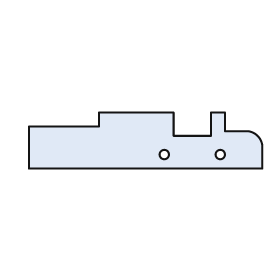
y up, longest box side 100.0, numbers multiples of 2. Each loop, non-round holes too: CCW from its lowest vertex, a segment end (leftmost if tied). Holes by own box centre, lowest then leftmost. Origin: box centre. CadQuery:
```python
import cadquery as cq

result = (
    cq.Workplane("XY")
    .moveTo(-50.0, -12.0)
    .lineTo(50.0, -12.0)
    .lineTo(50.0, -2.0)
    .threePointArc((48.0, 2.0), (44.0, 4.0))
    .lineTo(34.0, 4.0)
    .lineTo(34.0, 12.0)
    .lineTo(28.0, 12.0)
    .lineTo(28.0, 2.0)
    .lineTo(12.0, 2.0)
    .lineTo(12.0, 12.0)
    .lineTo(-20.0, 12.0)
    .lineTo(-20.0, 6.0)
    .lineTo(-50.0, 6.0)
    .close()
    .moveTo(8.0, -6.0)
    .circle(2.0)
    .moveTo(32.0, -6.0)
    .circle(2.0)
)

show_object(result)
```